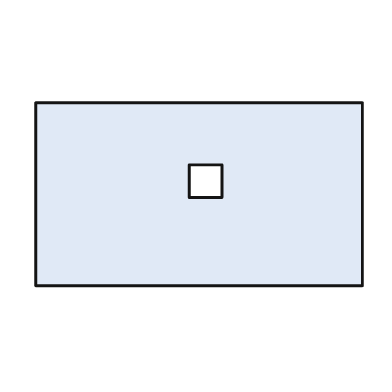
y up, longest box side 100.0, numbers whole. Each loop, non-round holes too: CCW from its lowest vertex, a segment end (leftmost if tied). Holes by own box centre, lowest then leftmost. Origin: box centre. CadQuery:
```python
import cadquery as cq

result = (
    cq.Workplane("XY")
    .moveTo(-50.0, -28.0)
    .lineTo(50.0, -28.0)
    .lineTo(50.0, 28.0)
    .lineTo(-50.0, 28.0)
    .close()
    .moveTo(-3.0, -1.0)
    .lineTo(7.0, -1.0)
    .lineTo(7.0, 9.0)
    .lineTo(-3.0, 9.0)
    .close()
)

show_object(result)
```